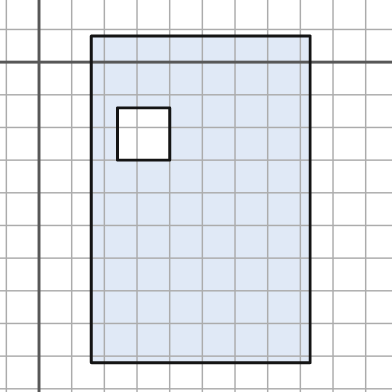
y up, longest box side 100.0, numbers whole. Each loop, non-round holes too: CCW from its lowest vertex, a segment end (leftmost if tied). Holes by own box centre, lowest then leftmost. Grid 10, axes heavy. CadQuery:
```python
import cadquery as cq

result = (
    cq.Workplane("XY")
    .moveTo(16.0, -92.0)
    .lineTo(83.0, -92.0)
    .lineTo(83.0, 8.0)
    .lineTo(16.0, 8.0)
    .close()
    .moveTo(24.0, -30.0)
    .lineTo(40.0, -30.0)
    .lineTo(40.0, -14.0)
    .lineTo(24.0, -14.0)
    .close()
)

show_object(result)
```